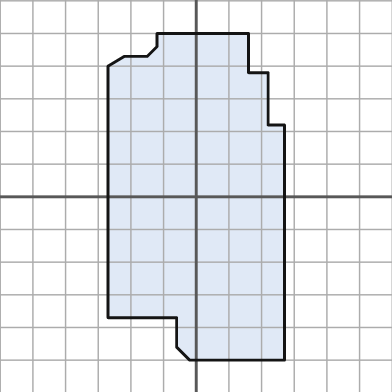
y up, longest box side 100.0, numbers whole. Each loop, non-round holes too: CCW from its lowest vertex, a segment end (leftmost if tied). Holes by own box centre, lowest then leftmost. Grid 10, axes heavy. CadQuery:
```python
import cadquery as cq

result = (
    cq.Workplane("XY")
    .moveTo(-2.0, -50.0)
    .lineTo(27.0, -50.0)
    .lineTo(27.0, 22.0)
    .lineTo(22.0, 22.0)
    .lineTo(22.0, 38.0)
    .lineTo(16.0, 38.0)
    .lineTo(16.0, 50.0)
    .lineTo(-12.0, 50.0)
    .lineTo(-12.0, 46.0)
    .lineTo(-15.0, 43.0)
    .lineTo(-22.0, 43.0)
    .lineTo(-27.0, 40.0)
    .lineTo(-27.0, -37.0)
    .lineTo(-6.0, -37.0)
    .lineTo(-6.0, -46.0)
    .close()
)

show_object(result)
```